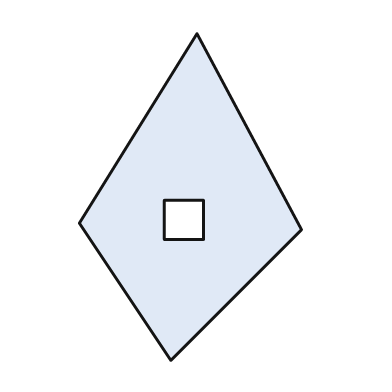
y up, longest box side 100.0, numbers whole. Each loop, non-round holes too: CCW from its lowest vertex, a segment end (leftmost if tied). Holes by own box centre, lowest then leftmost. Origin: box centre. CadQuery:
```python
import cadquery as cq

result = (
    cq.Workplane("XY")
    .moveTo(-6.0, -50.0)
    .lineTo(34.0, -10.0)
    .lineTo(2.0, 50.0)
    .lineTo(-34.0, -8.0)
    .close()
    .moveTo(-8.0, -13.0)
    .lineTo(4.0, -13.0)
    .lineTo(4.0, -1.0)
    .lineTo(-8.0, -1.0)
    .close()
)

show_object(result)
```